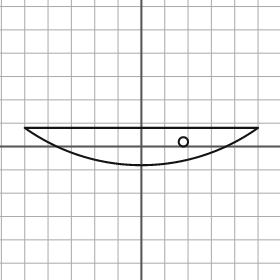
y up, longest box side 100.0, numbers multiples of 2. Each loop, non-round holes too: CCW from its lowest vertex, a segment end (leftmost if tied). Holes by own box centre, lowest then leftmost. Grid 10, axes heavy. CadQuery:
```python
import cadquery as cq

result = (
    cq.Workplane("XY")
    .moveTo(-50.0, 8.0)
    .threePointArc((0.0, -8.0), (50.0, 8.0))
    .close()
    .moveTo(18.0, 2.0)
    .circle(2.0)
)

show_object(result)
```